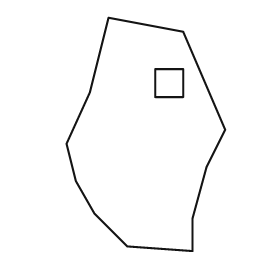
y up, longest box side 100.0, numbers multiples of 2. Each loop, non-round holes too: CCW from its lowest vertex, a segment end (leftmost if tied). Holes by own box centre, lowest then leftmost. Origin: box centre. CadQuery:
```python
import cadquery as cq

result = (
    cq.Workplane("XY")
    .moveTo(20.0, -50.0)
    .lineTo(20.0, -36.0)
    .lineTo(26.0, -14.0)
    .lineTo(34.0, 2.0)
    .lineTo(16.0, 44.0)
    .lineTo(-16.0, 50.0)
    .lineTo(-24.0, 18.0)
    .lineTo(-34.0, -4.0)
    .lineTo(-30.0, -20.0)
    .lineTo(-22.0, -34.0)
    .lineTo(-8.0, -48.0)
    .close()
    .moveTo(4.0, 16.0)
    .lineTo(16.0, 16.0)
    .lineTo(16.0, 28.0)
    .lineTo(4.0, 28.0)
    .close()
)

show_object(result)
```